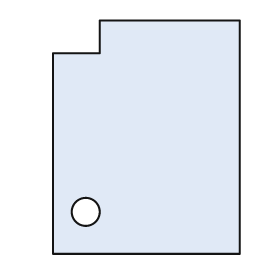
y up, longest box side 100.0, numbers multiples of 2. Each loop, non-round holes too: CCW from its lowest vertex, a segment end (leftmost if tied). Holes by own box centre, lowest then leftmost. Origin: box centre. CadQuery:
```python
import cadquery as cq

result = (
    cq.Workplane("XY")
    .moveTo(-40.0, -50.0)
    .lineTo(40.0, -50.0)
    .lineTo(40.0, 50.0)
    .lineTo(-20.0, 50.0)
    .lineTo(-20.0, 36.0)
    .lineTo(-40.0, 36.0)
    .close()
    .moveTo(-26.0, -32.0)
    .circle(6.0)
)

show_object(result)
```